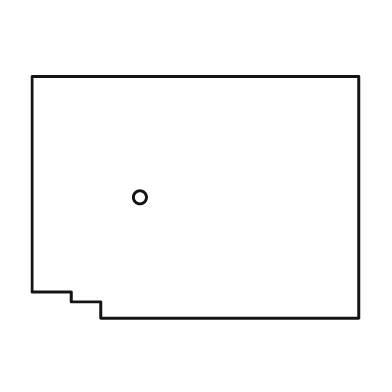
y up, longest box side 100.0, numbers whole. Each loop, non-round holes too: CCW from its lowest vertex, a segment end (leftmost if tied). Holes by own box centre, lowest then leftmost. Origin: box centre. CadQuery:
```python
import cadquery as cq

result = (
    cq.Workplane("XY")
    .moveTo(-29.0, -37.0)
    .lineTo(50.0, -37.0)
    .lineTo(50.0, 37.0)
    .lineTo(-50.0, 37.0)
    .lineTo(-50.0, -29.0)
    .lineTo(-38.0, -29.0)
    .lineTo(-38.0, -32.0)
    .lineTo(-29.0, -32.0)
    .close()
    .moveTo(-17.0, 0.0)
    .circle(2.0)
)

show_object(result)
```